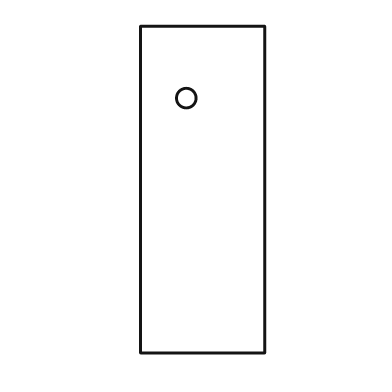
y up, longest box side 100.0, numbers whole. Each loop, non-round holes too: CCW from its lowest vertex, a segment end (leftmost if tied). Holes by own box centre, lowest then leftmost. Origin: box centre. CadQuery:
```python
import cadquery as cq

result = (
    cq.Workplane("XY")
    .moveTo(-19.0, -50.0)
    .lineTo(19.0, -50.0)
    .lineTo(19.0, 50.0)
    .lineTo(-19.0, 50.0)
    .close()
    .moveTo(-5.0, 28.0)
    .circle(3.0)
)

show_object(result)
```